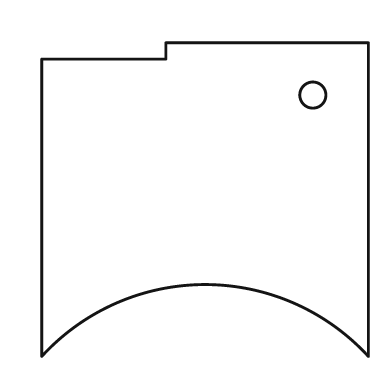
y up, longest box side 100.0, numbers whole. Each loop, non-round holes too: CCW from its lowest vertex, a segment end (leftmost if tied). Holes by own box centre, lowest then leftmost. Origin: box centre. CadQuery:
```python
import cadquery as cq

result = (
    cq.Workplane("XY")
    .moveTo(-50.0, -48.0)
    .threePointArc((0.0, -26.0), (50.0, -48.0))
    .lineTo(50.0, 48.0)
    .lineTo(-12.0, 48.0)
    .lineTo(-12.0, 43.0)
    .lineTo(-50.0, 43.0)
    .close()
    .moveTo(33.0, 32.0)
    .circle(4.0)
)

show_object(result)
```